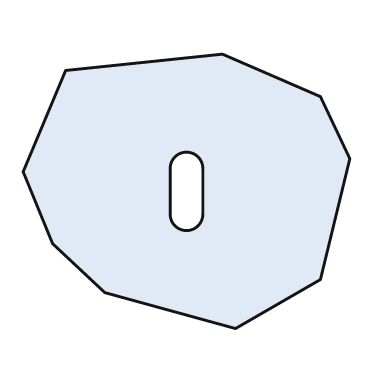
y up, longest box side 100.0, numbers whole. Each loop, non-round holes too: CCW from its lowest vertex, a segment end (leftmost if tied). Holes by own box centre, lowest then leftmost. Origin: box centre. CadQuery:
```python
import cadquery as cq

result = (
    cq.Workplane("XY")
    .moveTo(15.0, -42.0)
    .lineTo(41.0, -27.0)
    .lineTo(50.0, 10.0)
    .lineTo(41.0, 29.0)
    .lineTo(11.0, 42.0)
    .lineTo(-37.0, 37.0)
    .lineTo(-50.0, 6.0)
    .lineTo(-41.0, -16.0)
    .lineTo(-25.0, -31.0)
    .close()
    .moveTo(-5.0, -7.0)
    .threePointArc((0.0, -12.0), (5.0, -7.0))
    .lineTo(5.0, 7.0)
    .threePointArc((0.0, 12.0), (-5.0, 7.0))
    .close()
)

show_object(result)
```